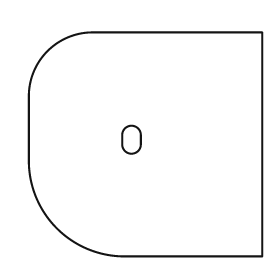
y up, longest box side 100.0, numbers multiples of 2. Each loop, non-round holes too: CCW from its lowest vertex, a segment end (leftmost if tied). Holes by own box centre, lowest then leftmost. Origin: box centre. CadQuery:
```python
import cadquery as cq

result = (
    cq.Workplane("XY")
    .moveTo(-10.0, -48.0)
    .lineTo(50.0, -48.0)
    .lineTo(50.0, 48.0)
    .lineTo(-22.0, 48.0)
    .threePointArc((-42.0, 40.0), (-50.0, 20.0))
    .lineTo(-50.0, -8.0)
    .threePointArc((-38.0, -36.0), (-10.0, -48.0))
    .close()
    .moveTo(-10.0, 0.0)
    .threePointArc((-6.0, -4.0), (-2.0, 0.0))
    .lineTo(-2.0, 4.0)
    .threePointArc((-6.0, 8.0), (-10.0, 4.0))
    .close()
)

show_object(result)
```